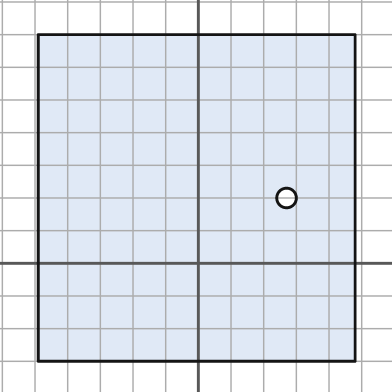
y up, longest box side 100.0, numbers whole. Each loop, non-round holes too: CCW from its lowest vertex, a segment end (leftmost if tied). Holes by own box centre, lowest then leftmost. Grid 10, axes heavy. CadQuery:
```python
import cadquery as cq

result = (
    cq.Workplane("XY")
    .moveTo(-49.0, -30.0)
    .lineTo(48.0, -30.0)
    .lineTo(48.0, 70.0)
    .lineTo(-49.0, 70.0)
    .close()
    .moveTo(27.0, 20.0)
    .circle(3.0)
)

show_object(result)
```